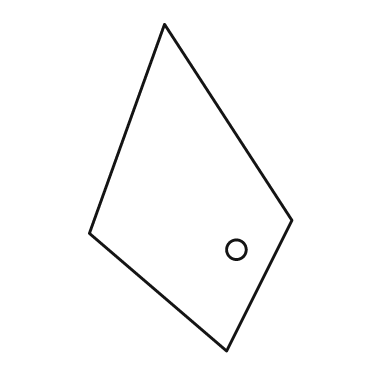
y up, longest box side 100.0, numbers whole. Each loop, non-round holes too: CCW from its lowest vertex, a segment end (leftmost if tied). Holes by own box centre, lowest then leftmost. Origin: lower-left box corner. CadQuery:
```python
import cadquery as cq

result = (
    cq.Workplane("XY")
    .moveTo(42.0, 0.0)
    .lineTo(62.0, 40.0)
    .lineTo(23.0, 100.0)
    .lineTo(0.0, 36.0)
    .close()
    .moveTo(45.0, 31.0)
    .circle(3.0)
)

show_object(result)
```